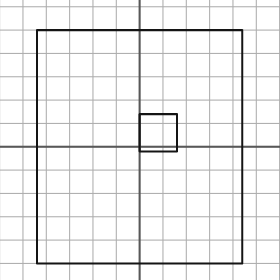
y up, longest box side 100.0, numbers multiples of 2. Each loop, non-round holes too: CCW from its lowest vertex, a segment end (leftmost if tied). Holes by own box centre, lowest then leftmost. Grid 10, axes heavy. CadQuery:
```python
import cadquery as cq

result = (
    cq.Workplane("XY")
    .moveTo(-44.0, -50.0)
    .lineTo(44.0, -50.0)
    .lineTo(44.0, 50.0)
    .lineTo(-44.0, 50.0)
    .close()
    .moveTo(0.0, -2.0)
    .lineTo(16.0, -2.0)
    .lineTo(16.0, 14.0)
    .lineTo(0.0, 14.0)
    .close()
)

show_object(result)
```